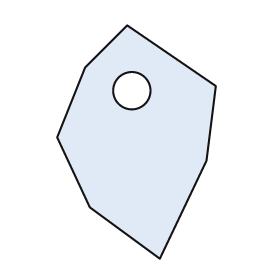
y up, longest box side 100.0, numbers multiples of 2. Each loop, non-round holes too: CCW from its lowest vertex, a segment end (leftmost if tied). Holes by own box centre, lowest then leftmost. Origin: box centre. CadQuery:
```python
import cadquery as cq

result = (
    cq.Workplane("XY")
    .moveTo(10.0, -50.0)
    .lineTo(30.0, -8.0)
    .lineTo(34.0, 24.0)
    .lineTo(-4.0, 50.0)
    .lineTo(-22.0, 32.0)
    .lineTo(-34.0, 2.0)
    .lineTo(-20.0, -28.0)
    .close()
    .moveTo(-2.0, 22.0)
    .circle(8.0)
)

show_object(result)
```